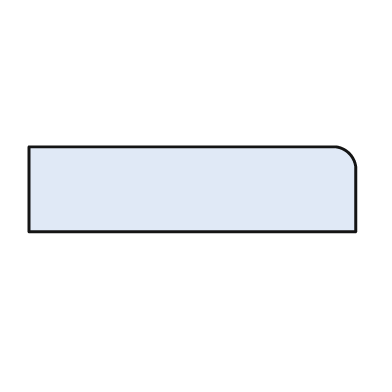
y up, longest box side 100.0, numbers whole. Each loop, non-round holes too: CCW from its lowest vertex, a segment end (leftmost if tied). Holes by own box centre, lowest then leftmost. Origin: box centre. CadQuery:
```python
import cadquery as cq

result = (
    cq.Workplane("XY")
    .moveTo(-50.0, -13.0)
    .lineTo(50.0, -13.0)
    .lineTo(50.0, 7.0)
    .threePointArc((48.0, 11.0), (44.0, 13.0))
    .lineTo(-50.0, 13.0)
    .close()
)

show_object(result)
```